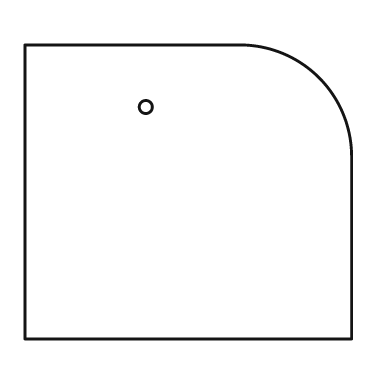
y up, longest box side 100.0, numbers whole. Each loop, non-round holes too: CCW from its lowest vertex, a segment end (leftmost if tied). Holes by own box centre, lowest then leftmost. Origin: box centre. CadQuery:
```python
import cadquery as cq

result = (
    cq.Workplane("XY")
    .moveTo(-50.0, -45.0)
    .lineTo(50.0, -45.0)
    .lineTo(50.0, 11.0)
    .threePointArc((40.0, 35.0), (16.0, 45.0))
    .lineTo(-50.0, 45.0)
    .close()
    .moveTo(-13.0, 26.0)
    .circle(2.0)
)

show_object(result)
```